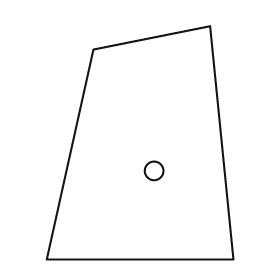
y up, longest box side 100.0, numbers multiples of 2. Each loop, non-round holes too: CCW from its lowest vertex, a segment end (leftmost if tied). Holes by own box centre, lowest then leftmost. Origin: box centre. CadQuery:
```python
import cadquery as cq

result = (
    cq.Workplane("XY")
    .moveTo(-40.0, -50.0)
    .lineTo(40.0, -50.0)
    .lineTo(30.0, 50.0)
    .lineTo(-20.0, 40.0)
    .close()
    .moveTo(6.0, -12.0)
    .circle(4.0)
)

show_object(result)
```